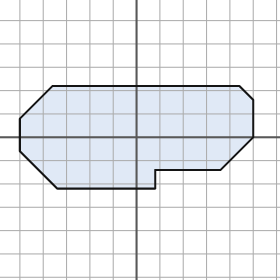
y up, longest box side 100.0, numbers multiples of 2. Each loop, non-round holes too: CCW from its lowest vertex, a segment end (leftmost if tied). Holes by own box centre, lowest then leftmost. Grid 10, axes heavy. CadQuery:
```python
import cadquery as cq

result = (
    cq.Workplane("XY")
    .moveTo(-34.0, -22.0)
    .lineTo(8.0, -22.0)
    .lineTo(8.0, -14.0)
    .lineTo(36.0, -14.0)
    .lineTo(50.0, 0.0)
    .lineTo(50.0, 16.0)
    .lineTo(44.0, 22.0)
    .lineTo(-36.0, 22.0)
    .lineTo(-50.0, 8.0)
    .lineTo(-50.0, -6.0)
    .close()
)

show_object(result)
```